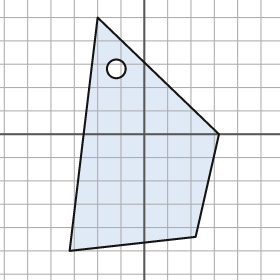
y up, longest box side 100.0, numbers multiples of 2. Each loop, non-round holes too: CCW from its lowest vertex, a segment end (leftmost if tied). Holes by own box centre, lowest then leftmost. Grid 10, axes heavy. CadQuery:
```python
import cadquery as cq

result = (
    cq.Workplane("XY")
    .moveTo(-32.0, -50.0)
    .lineTo(22.0, -44.0)
    .lineTo(32.0, 0.0)
    .lineTo(-20.0, 50.0)
    .close()
    .moveTo(-12.0, 28.0)
    .circle(4.0)
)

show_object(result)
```